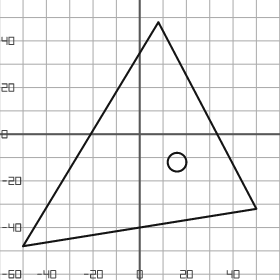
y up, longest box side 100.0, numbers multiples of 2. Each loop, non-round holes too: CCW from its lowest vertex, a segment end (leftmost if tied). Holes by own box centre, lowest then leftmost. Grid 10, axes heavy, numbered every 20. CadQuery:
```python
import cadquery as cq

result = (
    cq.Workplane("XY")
    .moveTo(-50.0, -48.0)
    .lineTo(50.0, -32.0)
    .lineTo(8.0, 48.0)
    .close()
    .moveTo(16.0, -12.0)
    .circle(4.0)
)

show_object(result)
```